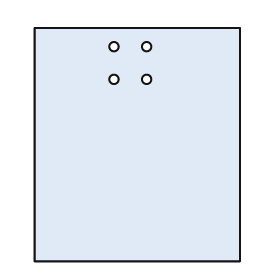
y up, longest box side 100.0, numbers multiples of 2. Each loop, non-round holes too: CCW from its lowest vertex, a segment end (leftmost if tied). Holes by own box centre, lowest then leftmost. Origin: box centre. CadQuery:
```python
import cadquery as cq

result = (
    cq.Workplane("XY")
    .moveTo(-44.0, -50.0)
    .lineTo(44.0, -50.0)
    .lineTo(44.0, 50.0)
    .lineTo(-44.0, 50.0)
    .close()
    .moveTo(-10.0, 28.0)
    .circle(2.0)
    .moveTo(4.0, 28.0)
    .circle(2.0)
    .moveTo(-10.0, 42.0)
    .circle(2.0)
    .moveTo(4.0, 42.0)
    .circle(2.0)
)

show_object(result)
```